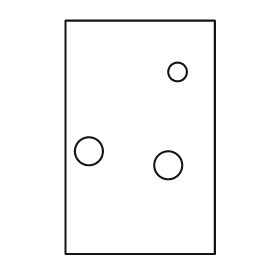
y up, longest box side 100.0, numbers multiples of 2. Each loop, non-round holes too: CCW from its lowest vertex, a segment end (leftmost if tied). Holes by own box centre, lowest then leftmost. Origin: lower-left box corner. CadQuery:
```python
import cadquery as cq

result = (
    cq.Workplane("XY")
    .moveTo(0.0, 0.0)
    .lineTo(64.0, 0.0)
    .lineTo(64.0, 100.0)
    .lineTo(0.0, 100.0)
    .close()
    .moveTo(44.0, 38.0)
    .circle(6.0)
    .moveTo(10.0, 44.0)
    .circle(6.0)
    .moveTo(48.0, 78.0)
    .circle(4.0)
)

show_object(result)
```